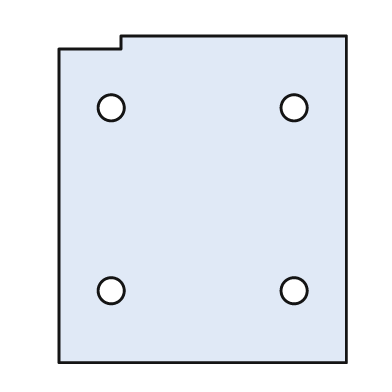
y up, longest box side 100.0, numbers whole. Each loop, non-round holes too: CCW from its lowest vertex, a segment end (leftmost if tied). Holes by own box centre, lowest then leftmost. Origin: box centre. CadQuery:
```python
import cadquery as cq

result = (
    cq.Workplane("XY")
    .moveTo(-44.0, -50.0)
    .lineTo(44.0, -50.0)
    .lineTo(44.0, 50.0)
    .lineTo(-25.0, 50.0)
    .lineTo(-25.0, 46.0)
    .lineTo(-44.0, 46.0)
    .close()
    .moveTo(-28.0, -28.0)
    .circle(4.0)
    .moveTo(28.0, -28.0)
    .circle(4.0)
    .moveTo(-28.0, 28.0)
    .circle(4.0)
    .moveTo(28.0, 28.0)
    .circle(4.0)
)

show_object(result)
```